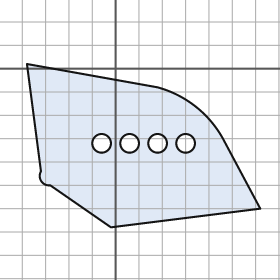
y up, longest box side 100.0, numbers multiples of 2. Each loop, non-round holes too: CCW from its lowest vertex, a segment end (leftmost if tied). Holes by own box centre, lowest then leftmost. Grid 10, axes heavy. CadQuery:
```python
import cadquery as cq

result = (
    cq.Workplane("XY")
    .moveTo(-2.0, -68.0)
    .lineTo(62.0, -60.0)
    .lineTo(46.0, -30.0)
    .threePointArc((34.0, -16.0), (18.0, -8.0))
    .lineTo(-38.0, 2.0)
    .lineTo(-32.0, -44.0)
    .threePointArc((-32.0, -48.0), (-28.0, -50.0))
    .close()
    .moveTo(-6.0, -32.0)
    .circle(4.0)
    .moveTo(6.0, -32.0)
    .circle(4.0)
    .moveTo(18.0, -32.0)
    .circle(4.0)
    .moveTo(30.0, -32.0)
    .circle(4.0)
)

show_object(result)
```